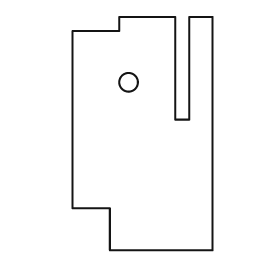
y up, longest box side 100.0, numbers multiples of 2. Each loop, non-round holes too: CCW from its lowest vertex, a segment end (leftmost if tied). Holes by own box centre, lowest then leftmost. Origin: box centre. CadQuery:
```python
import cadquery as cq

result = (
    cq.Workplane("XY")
    .moveTo(-14.0, -50.0)
    .lineTo(30.0, -50.0)
    .lineTo(30.0, 50.0)
    .lineTo(20.0, 50.0)
    .lineTo(20.0, 6.0)
    .lineTo(14.0, 6.0)
    .lineTo(14.0, 50.0)
    .lineTo(-10.0, 50.0)
    .lineTo(-10.0, 44.0)
    .lineTo(-30.0, 44.0)
    .lineTo(-30.0, -32.0)
    .lineTo(-14.0, -32.0)
    .close()
    .moveTo(-6.0, 22.0)
    .circle(4.0)
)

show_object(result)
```